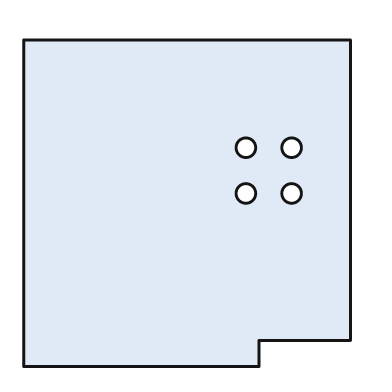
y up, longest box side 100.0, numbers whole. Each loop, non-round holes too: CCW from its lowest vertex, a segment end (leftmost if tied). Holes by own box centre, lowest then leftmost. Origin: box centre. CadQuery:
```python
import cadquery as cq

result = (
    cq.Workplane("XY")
    .moveTo(-50.0, -50.0)
    .lineTo(22.0, -50.0)
    .lineTo(22.0, -42.0)
    .lineTo(50.0, -42.0)
    .lineTo(50.0, 50.0)
    .lineTo(-50.0, 50.0)
    .close()
    .moveTo(18.0, 3.0)
    .circle(3.0)
    .moveTo(32.0, 3.0)
    .circle(3.0)
    .moveTo(18.0, 17.0)
    .circle(3.0)
    .moveTo(32.0, 17.0)
    .circle(3.0)
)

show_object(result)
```